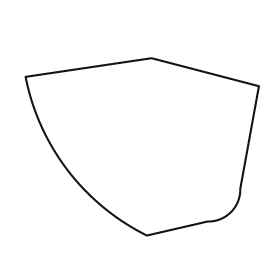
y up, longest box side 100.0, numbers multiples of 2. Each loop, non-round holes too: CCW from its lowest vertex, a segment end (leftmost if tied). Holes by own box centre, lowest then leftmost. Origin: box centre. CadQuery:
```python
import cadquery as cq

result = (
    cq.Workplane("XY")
    .moveTo(2.0, -38.0)
    .lineTo(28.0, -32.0)
    .threePointArc((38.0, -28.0), (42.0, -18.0))
    .lineTo(50.0, 26.0)
    .lineTo(4.0, 38.0)
    .lineTo(-50.0, 30.0)
    .threePointArc((-32.0, -10.0), (2.0, -38.0))
    .close()
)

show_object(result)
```